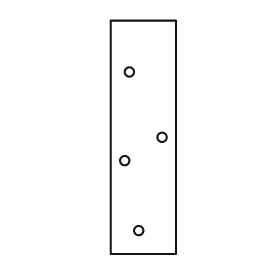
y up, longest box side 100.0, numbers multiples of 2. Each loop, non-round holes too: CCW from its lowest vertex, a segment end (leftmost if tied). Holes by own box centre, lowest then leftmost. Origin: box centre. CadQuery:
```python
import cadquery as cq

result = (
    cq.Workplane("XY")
    .moveTo(-14.0, -50.0)
    .lineTo(14.0, -50.0)
    .lineTo(14.0, 50.0)
    .lineTo(-14.0, 50.0)
    .close()
    .moveTo(-2.0, -40.0)
    .circle(2.0)
    .moveTo(-8.0, -10.0)
    .circle(2.0)
    .moveTo(8.0, 0.0)
    .circle(2.0)
    .moveTo(-6.0, 28.0)
    .circle(2.0)
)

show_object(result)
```